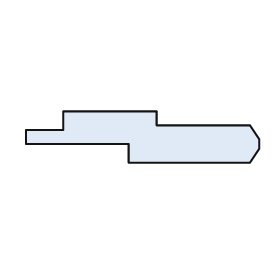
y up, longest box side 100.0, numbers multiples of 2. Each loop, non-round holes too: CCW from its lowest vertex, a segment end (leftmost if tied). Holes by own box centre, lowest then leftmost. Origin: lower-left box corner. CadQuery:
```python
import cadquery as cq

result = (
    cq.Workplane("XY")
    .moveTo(44.0, 0.0)
    .lineTo(96.0, 0.0)
    .lineTo(100.0, 6.0)
    .lineTo(100.0, 10.0)
    .lineTo(96.0, 16.0)
    .lineTo(56.0, 16.0)
    .lineTo(56.0, 22.0)
    .lineTo(16.0, 22.0)
    .lineTo(16.0, 14.0)
    .lineTo(0.0, 14.0)
    .lineTo(0.0, 8.0)
    .lineTo(44.0, 8.0)
    .close()
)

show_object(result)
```